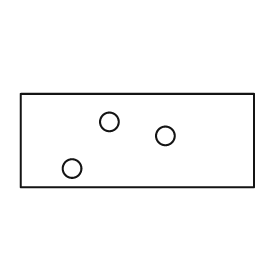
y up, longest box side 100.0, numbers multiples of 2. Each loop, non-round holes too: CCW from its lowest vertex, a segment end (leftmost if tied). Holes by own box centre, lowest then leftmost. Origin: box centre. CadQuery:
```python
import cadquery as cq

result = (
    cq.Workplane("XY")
    .moveTo(-50.0, -20.0)
    .lineTo(50.0, -20.0)
    .lineTo(50.0, 20.0)
    .lineTo(-50.0, 20.0)
    .close()
    .moveTo(-28.0, -12.0)
    .circle(4.0)
    .moveTo(12.0, 2.0)
    .circle(4.0)
    .moveTo(-12.0, 8.0)
    .circle(4.0)
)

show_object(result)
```